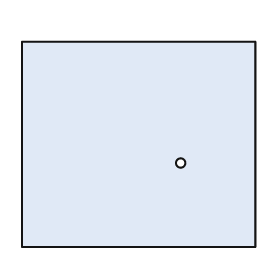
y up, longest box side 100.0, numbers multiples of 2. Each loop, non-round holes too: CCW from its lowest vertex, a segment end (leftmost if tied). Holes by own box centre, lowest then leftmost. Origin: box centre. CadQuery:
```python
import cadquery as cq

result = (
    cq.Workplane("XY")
    .moveTo(-50.0, -44.0)
    .lineTo(50.0, -44.0)
    .lineTo(50.0, 44.0)
    .lineTo(-50.0, 44.0)
    .close()
    .moveTo(18.0, -8.0)
    .circle(2.0)
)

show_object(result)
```